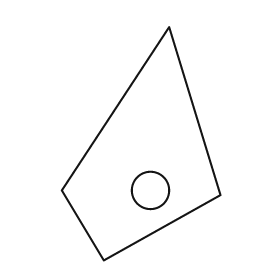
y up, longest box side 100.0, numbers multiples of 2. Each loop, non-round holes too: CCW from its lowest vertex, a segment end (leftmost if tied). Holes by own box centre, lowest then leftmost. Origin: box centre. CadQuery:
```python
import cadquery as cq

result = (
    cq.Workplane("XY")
    .moveTo(-16.0, -50.0)
    .lineTo(34.0, -22.0)
    .lineTo(12.0, 50.0)
    .lineTo(-34.0, -20.0)
    .close()
    .moveTo(4.0, -20.0)
    .circle(8.0)
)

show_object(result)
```